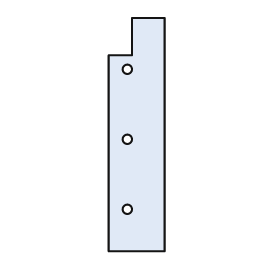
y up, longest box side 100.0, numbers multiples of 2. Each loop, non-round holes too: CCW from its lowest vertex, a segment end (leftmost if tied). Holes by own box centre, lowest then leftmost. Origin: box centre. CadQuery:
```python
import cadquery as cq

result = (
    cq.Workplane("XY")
    .moveTo(-12.0, -50.0)
    .lineTo(12.0, -50.0)
    .lineTo(12.0, 50.0)
    .lineTo(-2.0, 50.0)
    .lineTo(-2.0, 34.0)
    .lineTo(-12.0, 34.0)
    .close()
    .moveTo(-4.0, -32.0)
    .circle(2.0)
    .moveTo(-4.0, -2.0)
    .circle(2.0)
    .moveTo(-4.0, 28.0)
    .circle(2.0)
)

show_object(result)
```